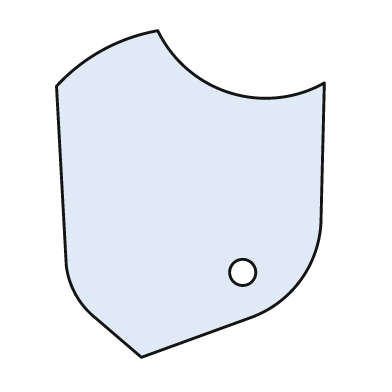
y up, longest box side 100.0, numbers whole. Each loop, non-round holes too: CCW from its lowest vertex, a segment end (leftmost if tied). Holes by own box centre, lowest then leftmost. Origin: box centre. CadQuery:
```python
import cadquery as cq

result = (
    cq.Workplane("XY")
    .moveTo(-15.0, -50.0)
    .lineTo(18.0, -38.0)
    .threePointArc((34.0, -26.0), (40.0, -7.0))
    .lineTo(41.0, 34.0)
    .threePointArc((12.0, 31.0), (-10.0, 50.0))
    .threePointArc((-27.0, 44.0), (-41.0, 33.0))
    .lineTo(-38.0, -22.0)
    .threePointArc((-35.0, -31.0), (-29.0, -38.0))
    .close()
    .moveTo(16.0, -24.0)
    .circle(4.0)
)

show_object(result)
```